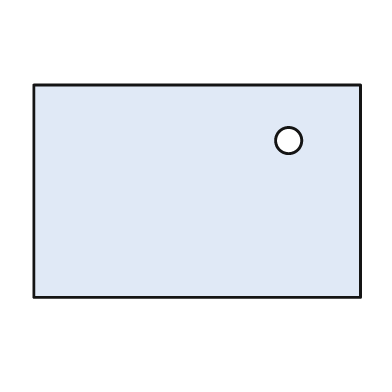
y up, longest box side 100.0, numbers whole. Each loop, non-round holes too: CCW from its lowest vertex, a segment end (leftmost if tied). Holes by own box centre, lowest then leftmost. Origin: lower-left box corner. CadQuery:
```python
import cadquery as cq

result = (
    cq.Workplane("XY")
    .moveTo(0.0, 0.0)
    .lineTo(100.0, 0.0)
    .lineTo(100.0, 65.0)
    .lineTo(0.0, 65.0)
    .close()
    .moveTo(78.0, 48.0)
    .circle(4.0)
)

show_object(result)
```